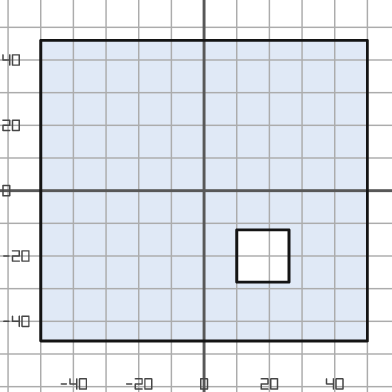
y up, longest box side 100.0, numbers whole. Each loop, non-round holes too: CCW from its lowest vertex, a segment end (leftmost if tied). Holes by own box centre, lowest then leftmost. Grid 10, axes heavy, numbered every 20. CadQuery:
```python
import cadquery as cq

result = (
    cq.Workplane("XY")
    .moveTo(-50.0, -46.0)
    .lineTo(50.0, -46.0)
    .lineTo(50.0, 46.0)
    .lineTo(-50.0, 46.0)
    .close()
    .moveTo(10.0, -28.0)
    .lineTo(26.0, -28.0)
    .lineTo(26.0, -12.0)
    .lineTo(10.0, -12.0)
    .close()
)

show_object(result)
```